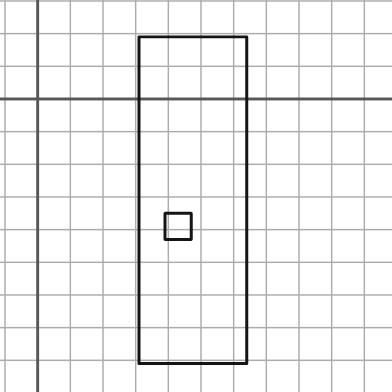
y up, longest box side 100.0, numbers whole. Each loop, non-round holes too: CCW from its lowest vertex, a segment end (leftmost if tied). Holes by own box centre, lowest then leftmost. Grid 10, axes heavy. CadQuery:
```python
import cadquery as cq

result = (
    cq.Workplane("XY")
    .moveTo(31.0, -81.0)
    .lineTo(64.0, -81.0)
    .lineTo(64.0, 19.0)
    .lineTo(31.0, 19.0)
    .close()
    .moveTo(39.0, -43.0)
    .lineTo(47.0, -43.0)
    .lineTo(47.0, -35.0)
    .lineTo(39.0, -35.0)
    .close()
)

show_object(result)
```